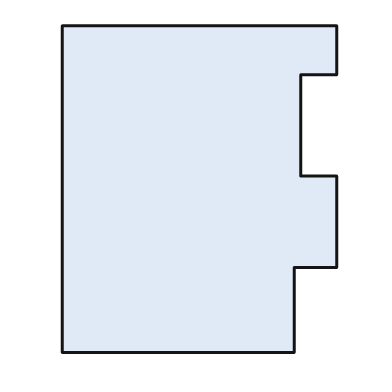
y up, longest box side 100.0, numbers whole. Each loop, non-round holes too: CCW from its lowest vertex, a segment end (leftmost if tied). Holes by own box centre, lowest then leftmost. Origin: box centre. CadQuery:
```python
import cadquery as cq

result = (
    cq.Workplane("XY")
    .moveTo(-42.0, -50.0)
    .lineTo(29.0, -50.0)
    .lineTo(29.0, -24.0)
    .lineTo(42.0, -24.0)
    .lineTo(42.0, 4.0)
    .lineTo(31.0, 4.0)
    .lineTo(31.0, 35.0)
    .lineTo(42.0, 35.0)
    .lineTo(42.0, 50.0)
    .lineTo(-42.0, 50.0)
    .close()
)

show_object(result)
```